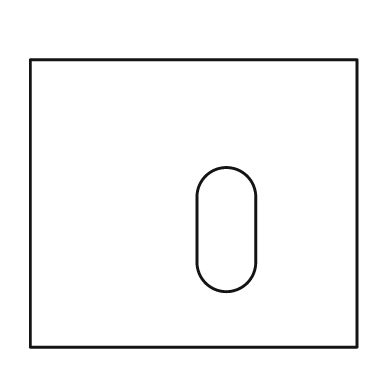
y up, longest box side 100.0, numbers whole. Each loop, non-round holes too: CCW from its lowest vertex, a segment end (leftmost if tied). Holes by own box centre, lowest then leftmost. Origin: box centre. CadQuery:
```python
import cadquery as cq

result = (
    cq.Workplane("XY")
    .moveTo(-50.0, -44.0)
    .lineTo(50.0, -44.0)
    .lineTo(50.0, 44.0)
    .lineTo(-50.0, 44.0)
    .close()
    .moveTo(1.0, -18.0)
    .threePointArc((10.0, -27.0), (19.0, -18.0))
    .lineTo(19.0, 2.0)
    .threePointArc((10.0, 11.0), (1.0, 2.0))
    .close()
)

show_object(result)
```